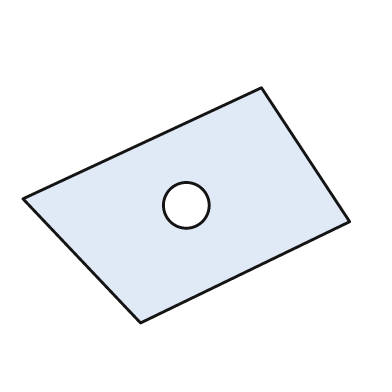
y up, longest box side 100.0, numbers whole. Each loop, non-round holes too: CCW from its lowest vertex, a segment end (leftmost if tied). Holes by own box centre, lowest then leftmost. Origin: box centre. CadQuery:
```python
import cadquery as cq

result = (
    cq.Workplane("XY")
    .moveTo(-14.0, -36.0)
    .lineTo(50.0, -5.0)
    .lineTo(23.0, 36.0)
    .lineTo(-50.0, 2.0)
    .close()
    .moveTo(0.0, 0.0)
    .circle(7.0)
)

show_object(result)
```